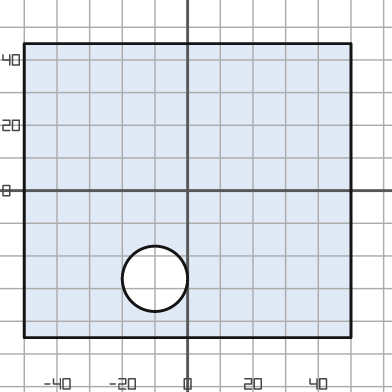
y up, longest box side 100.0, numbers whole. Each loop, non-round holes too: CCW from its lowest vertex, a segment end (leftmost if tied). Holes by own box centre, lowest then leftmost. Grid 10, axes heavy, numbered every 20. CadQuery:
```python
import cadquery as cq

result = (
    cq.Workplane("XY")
    .moveTo(-50.0, -45.0)
    .lineTo(50.0, -45.0)
    .lineTo(50.0, 45.0)
    .lineTo(-50.0, 45.0)
    .close()
    .moveTo(-10.0, -27.0)
    .circle(10.0)
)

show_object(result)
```